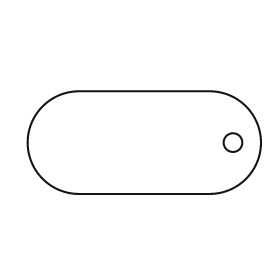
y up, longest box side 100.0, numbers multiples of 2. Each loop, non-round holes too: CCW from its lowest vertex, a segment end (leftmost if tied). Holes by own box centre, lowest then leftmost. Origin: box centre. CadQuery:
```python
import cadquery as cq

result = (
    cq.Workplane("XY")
    .moveTo(-28.0, -22.0)
    .lineTo(28.0, -22.0)
    .threePointArc((50.0, 0.0), (28.0, 22.0))
    .lineTo(-28.0, 22.0)
    .threePointArc((-50.0, 0.0), (-28.0, -22.0))
    .close()
    .moveTo(38.0, 0.0)
    .circle(4.0)
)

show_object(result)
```